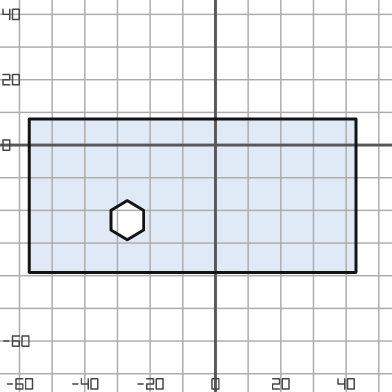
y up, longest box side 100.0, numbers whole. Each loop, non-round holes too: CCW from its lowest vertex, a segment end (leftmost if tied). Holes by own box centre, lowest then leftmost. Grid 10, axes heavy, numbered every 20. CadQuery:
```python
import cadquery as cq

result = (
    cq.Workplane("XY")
    .moveTo(-57.0, -39.0)
    .lineTo(43.0, -39.0)
    .lineTo(43.0, 8.0)
    .lineTo(-57.0, 8.0)
    .close()
    .moveTo(-27.0, -29.0)
    .lineTo(-22.0, -26.0)
    .lineTo(-22.0, -20.0)
    .lineTo(-27.0, -17.0)
    .lineTo(-32.0, -20.0)
    .lineTo(-32.0, -26.0)
    .close()
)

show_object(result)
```